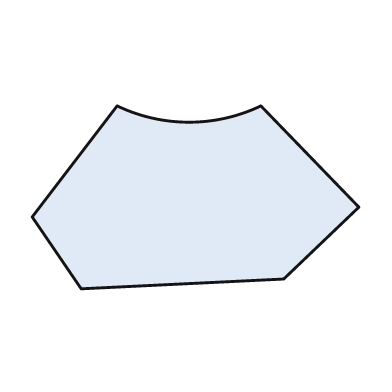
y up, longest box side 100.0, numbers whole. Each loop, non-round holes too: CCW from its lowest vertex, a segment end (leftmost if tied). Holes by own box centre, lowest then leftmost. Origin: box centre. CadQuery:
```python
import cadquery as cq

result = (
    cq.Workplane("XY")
    .moveTo(-35.0, -28.0)
    .lineTo(27.0, -25.0)
    .lineTo(50.0, -3.0)
    .lineTo(20.0, 28.0)
    .threePointArc((-2.0, 23.0), (-24.0, 28.0))
    .lineTo(-50.0, -6.0)
    .close()
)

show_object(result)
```